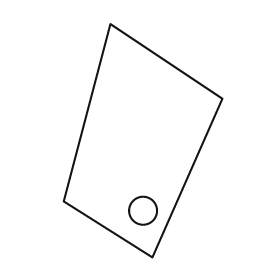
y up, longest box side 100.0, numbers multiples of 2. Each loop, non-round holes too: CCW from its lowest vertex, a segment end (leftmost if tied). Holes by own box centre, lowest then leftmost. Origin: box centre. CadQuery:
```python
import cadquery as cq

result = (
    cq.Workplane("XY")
    .moveTo(4.0, -50.0)
    .lineTo(34.0, 18.0)
    .lineTo(-14.0, 50.0)
    .lineTo(-34.0, -26.0)
    .close()
    .moveTo(0.0, -30.0)
    .circle(6.0)
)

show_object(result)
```